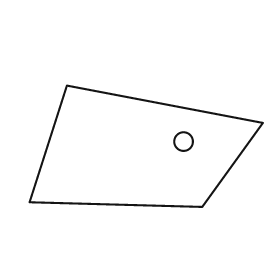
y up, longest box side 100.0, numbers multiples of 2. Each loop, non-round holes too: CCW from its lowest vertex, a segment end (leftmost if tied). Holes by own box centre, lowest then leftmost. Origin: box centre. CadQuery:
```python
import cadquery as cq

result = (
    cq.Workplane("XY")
    .moveTo(24.0, -26.0)
    .lineTo(50.0, 10.0)
    .lineTo(-34.0, 26.0)
    .lineTo(-50.0, -24.0)
    .close()
    .moveTo(16.0, 2.0)
    .circle(4.0)
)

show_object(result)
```